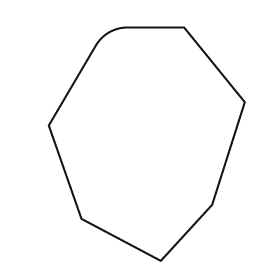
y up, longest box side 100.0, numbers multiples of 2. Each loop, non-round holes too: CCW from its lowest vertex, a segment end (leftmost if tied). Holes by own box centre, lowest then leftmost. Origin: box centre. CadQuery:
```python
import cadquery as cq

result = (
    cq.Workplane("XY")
    .moveTo(6.0, -50.0)
    .lineTo(28.0, -26.0)
    .lineTo(42.0, 18.0)
    .lineTo(16.0, 50.0)
    .lineTo(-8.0, 50.0)
    .threePointArc((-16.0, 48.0), (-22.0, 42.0))
    .lineTo(-42.0, 8.0)
    .lineTo(-28.0, -32.0)
    .close()
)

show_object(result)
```